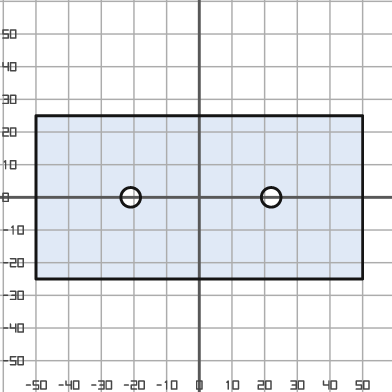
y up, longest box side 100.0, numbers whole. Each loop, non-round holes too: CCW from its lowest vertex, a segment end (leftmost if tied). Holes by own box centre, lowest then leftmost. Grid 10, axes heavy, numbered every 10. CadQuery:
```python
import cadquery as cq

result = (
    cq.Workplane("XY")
    .moveTo(-50.0, -25.0)
    .lineTo(50.0, -25.0)
    .lineTo(50.0, 25.0)
    .lineTo(-50.0, 25.0)
    .close()
    .moveTo(-21.0, 0.0)
    .circle(3.0)
    .moveTo(22.0, 0.0)
    .circle(3.0)
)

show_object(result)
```